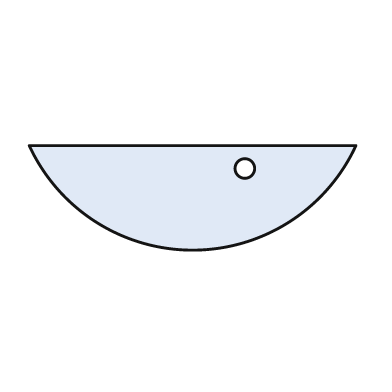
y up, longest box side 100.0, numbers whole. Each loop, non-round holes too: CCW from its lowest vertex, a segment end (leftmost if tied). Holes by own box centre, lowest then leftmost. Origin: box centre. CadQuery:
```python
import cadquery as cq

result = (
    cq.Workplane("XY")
    .moveTo(-50.0, 16.0)
    .threePointArc((0.0, -16.0), (50.0, 16.0))
    .close()
    .moveTo(16.0, 9.0)
    .circle(3.0)
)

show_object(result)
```